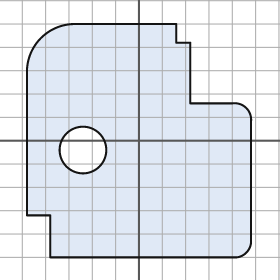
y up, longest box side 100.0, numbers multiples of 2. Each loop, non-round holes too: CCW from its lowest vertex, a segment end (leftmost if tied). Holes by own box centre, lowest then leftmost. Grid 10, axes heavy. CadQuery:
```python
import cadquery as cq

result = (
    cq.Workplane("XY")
    .moveTo(-38.0, -50.0)
    .lineTo(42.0, -50.0)
    .threePointArc((46.0, -48.0), (48.0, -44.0))
    .lineTo(48.0, 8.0)
    .threePointArc((46.0, 14.0), (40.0, 16.0))
    .lineTo(22.0, 16.0)
    .lineTo(22.0, 42.0)
    .lineTo(16.0, 42.0)
    .lineTo(16.0, 50.0)
    .lineTo(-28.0, 50.0)
    .threePointArc((-42.0, 44.0), (-48.0, 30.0))
    .lineTo(-48.0, -32.0)
    .lineTo(-38.0, -32.0)
    .close()
    .moveTo(-24.0, -4.0)
    .circle(10.0)
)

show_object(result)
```